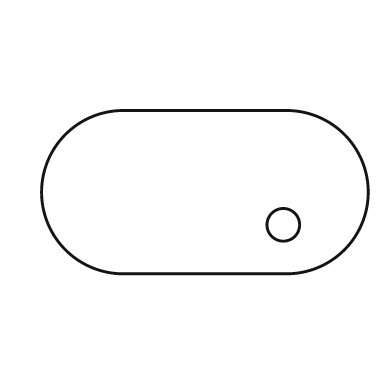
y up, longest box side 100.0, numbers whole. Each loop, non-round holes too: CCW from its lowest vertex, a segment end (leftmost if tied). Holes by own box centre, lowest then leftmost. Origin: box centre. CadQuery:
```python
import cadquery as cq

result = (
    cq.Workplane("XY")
    .moveTo(-25.0, -25.0)
    .lineTo(25.0, -25.0)
    .threePointArc((50.0, 0.0), (25.0, 25.0))
    .lineTo(-25.0, 25.0)
    .threePointArc((-50.0, 0.0), (-25.0, -25.0))
    .close()
    .moveTo(24.0, -10.0)
    .circle(5.0)
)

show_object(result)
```